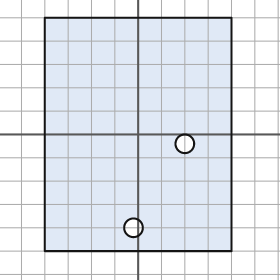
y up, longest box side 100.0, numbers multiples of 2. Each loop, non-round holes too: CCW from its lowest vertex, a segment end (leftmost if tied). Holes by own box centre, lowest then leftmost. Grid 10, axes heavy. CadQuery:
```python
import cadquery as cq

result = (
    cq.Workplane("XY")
    .moveTo(-40.0, -50.0)
    .lineTo(40.0, -50.0)
    .lineTo(40.0, 50.0)
    .lineTo(-40.0, 50.0)
    .close()
    .moveTo(-2.0, -40.0)
    .circle(4.0)
    .moveTo(20.0, -4.0)
    .circle(4.0)
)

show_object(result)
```